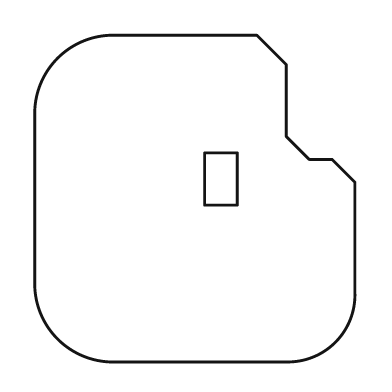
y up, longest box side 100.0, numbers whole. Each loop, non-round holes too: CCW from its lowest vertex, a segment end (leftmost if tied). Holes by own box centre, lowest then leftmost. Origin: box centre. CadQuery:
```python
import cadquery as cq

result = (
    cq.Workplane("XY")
    .moveTo(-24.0, -50.0)
    .lineTo(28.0, -50.0)
    .threePointArc((43.0, -44.0), (49.0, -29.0))
    .lineTo(49.0, 5.0)
    .lineTo(42.0, 12.0)
    .lineTo(35.0, 12.0)
    .lineTo(28.0, 19.0)
    .lineTo(28.0, 41.0)
    .lineTo(19.0, 50.0)
    .lineTo(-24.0, 50.0)
    .threePointArc((-42.0, 43.0), (-49.0, 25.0))
    .lineTo(-49.0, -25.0)
    .threePointArc((-42.0, -43.0), (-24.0, -50.0))
    .close()
    .moveTo(3.0, -2.0)
    .lineTo(13.0, -2.0)
    .lineTo(13.0, 14.0)
    .lineTo(3.0, 14.0)
    .close()
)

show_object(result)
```